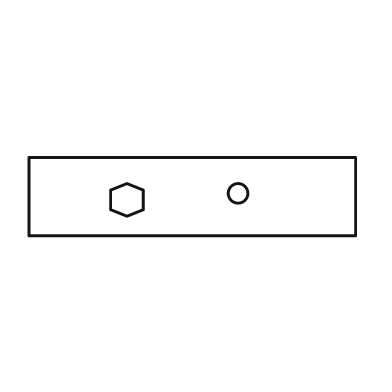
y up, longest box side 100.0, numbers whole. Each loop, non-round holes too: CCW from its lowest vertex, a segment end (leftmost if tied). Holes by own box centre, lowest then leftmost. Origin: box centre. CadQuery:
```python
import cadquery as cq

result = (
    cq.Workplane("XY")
    .moveTo(-50.0, -12.0)
    .lineTo(50.0, -12.0)
    .lineTo(50.0, 12.0)
    .lineTo(-50.0, 12.0)
    .close()
    .moveTo(-20.0, -6.0)
    .lineTo(-15.0, -4.0)
    .lineTo(-15.0, 2.0)
    .lineTo(-20.0, 4.0)
    .lineTo(-25.0, 2.0)
    .lineTo(-25.0, -4.0)
    .close()
    .moveTo(14.0, 1.0)
    .circle(3.0)
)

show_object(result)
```